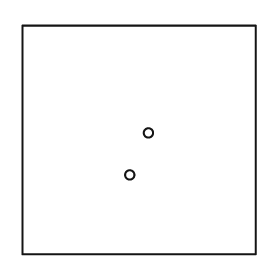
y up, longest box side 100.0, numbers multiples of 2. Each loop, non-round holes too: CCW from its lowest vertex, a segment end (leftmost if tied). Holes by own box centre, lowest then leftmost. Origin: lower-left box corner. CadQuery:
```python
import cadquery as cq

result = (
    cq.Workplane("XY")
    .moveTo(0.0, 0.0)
    .lineTo(100.0, 0.0)
    .lineTo(100.0, 98.0)
    .lineTo(0.0, 98.0)
    .close()
    .moveTo(46.0, 34.0)
    .circle(2.0)
    .moveTo(54.0, 52.0)
    .circle(2.0)
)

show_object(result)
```